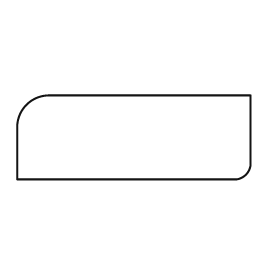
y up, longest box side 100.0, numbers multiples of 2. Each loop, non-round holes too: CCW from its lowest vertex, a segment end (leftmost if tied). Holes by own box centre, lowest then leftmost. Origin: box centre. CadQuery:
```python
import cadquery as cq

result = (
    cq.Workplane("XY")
    .moveTo(-50.0, -18.0)
    .lineTo(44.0, -18.0)
    .threePointArc((48.0, -16.0), (50.0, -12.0))
    .lineTo(50.0, 18.0)
    .lineTo(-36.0, 18.0)
    .threePointArc((-46.0, 14.0), (-50.0, 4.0))
    .close()
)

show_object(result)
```